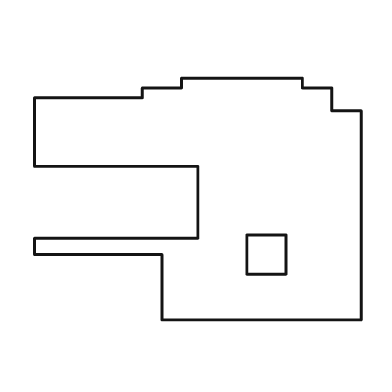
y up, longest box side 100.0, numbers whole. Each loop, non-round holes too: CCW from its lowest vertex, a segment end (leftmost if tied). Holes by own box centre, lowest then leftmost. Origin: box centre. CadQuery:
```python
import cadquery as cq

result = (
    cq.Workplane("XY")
    .moveTo(-11.0, -37.0)
    .lineTo(50.0, -37.0)
    .lineTo(50.0, 27.0)
    .lineTo(41.0, 27.0)
    .lineTo(41.0, 34.0)
    .lineTo(32.0, 34.0)
    .lineTo(32.0, 37.0)
    .lineTo(-5.0, 37.0)
    .lineTo(-5.0, 34.0)
    .lineTo(-17.0, 34.0)
    .lineTo(-17.0, 31.0)
    .lineTo(-50.0, 31.0)
    .lineTo(-50.0, 10.0)
    .lineTo(0.0, 10.0)
    .lineTo(0.0, -12.0)
    .lineTo(-50.0, -12.0)
    .lineTo(-50.0, -17.0)
    .lineTo(-11.0, -17.0)
    .close()
    .moveTo(15.0, -23.0)
    .lineTo(27.0, -23.0)
    .lineTo(27.0, -11.0)
    .lineTo(15.0, -11.0)
    .close()
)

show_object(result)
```